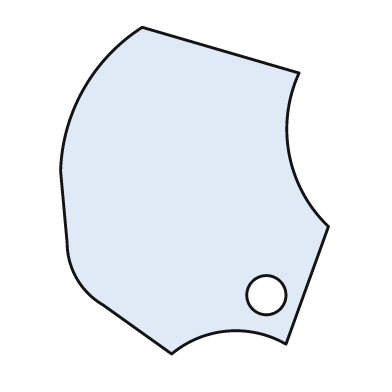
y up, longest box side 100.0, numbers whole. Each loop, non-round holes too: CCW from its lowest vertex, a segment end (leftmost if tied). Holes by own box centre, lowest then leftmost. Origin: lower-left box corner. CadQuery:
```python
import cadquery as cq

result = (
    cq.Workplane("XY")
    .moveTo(34.0, 0.0)
    .threePointArc((51.0, 7.0), (69.0, 3.0))
    .lineTo(82.0, 39.0)
    .threePointArc((70.0, 61.0), (73.0, 86.0))
    .lineTo(25.0, 100.0)
    .threePointArc((7.0, 81.0), (0.0, 56.0))
    .lineTo(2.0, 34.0)
    .threePointArc((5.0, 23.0), (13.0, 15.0))
    .close()
    .moveTo(63.0, 18.0)
    .circle(6.0)
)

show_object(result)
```